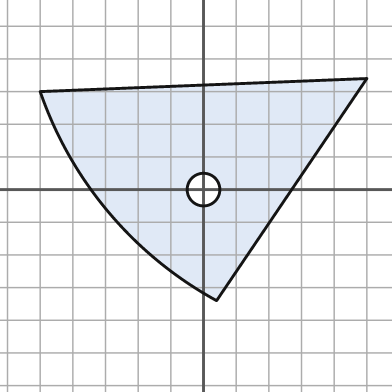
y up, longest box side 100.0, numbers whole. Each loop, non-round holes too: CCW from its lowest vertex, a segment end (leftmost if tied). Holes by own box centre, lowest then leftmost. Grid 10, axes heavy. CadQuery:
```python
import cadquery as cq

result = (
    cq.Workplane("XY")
    .moveTo(4.0, -34.0)
    .lineTo(50.0, 34.0)
    .lineTo(-50.0, 30.0)
    .threePointArc((-29.0, -7.0), (4.0, -34.0))
    .close()
    .moveTo(0.0, 0.0)
    .circle(5.0)
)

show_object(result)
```